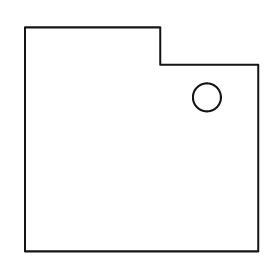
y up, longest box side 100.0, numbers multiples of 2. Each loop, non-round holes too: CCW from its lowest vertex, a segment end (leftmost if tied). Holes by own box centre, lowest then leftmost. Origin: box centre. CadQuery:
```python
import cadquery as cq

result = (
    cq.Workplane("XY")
    .moveTo(-50.0, -48.0)
    .lineTo(50.0, -48.0)
    .lineTo(50.0, 32.0)
    .lineTo(8.0, 32.0)
    .lineTo(8.0, 48.0)
    .lineTo(-50.0, 48.0)
    .close()
    .moveTo(28.0, 18.0)
    .circle(6.0)
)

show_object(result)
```